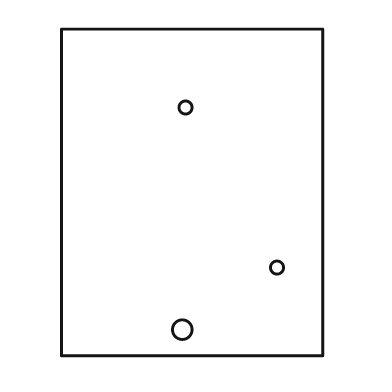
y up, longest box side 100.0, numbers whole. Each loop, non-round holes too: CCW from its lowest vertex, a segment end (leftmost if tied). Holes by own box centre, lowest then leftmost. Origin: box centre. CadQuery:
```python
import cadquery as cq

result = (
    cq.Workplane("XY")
    .moveTo(-40.0, -50.0)
    .lineTo(40.0, -50.0)
    .lineTo(40.0, 50.0)
    .lineTo(-40.0, 50.0)
    .close()
    .moveTo(-3.0, -42.0)
    .circle(3.0)
    .moveTo(26.0, -23.0)
    .circle(2.0)
    .moveTo(-2.0, 26.0)
    .circle(2.0)
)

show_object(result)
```